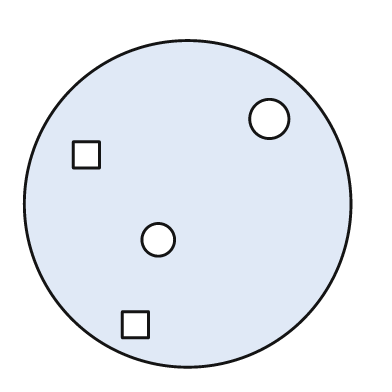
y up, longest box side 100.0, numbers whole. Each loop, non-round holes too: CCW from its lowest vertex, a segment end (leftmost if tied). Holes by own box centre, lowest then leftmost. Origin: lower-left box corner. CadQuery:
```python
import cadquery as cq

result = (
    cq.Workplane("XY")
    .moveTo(50.0, 50.0)
    .circle(50.0)
    .moveTo(30.0, 9.0)
    .lineTo(38.0, 9.0)
    .lineTo(38.0, 17.0)
    .lineTo(30.0, 17.0)
    .close()
    .moveTo(41.0, 39.0)
    .circle(5.0)
    .moveTo(15.0, 61.0)
    .lineTo(23.0, 61.0)
    .lineTo(23.0, 69.0)
    .lineTo(15.0, 69.0)
    .close()
    .moveTo(75.0, 76.0)
    .circle(6.0)
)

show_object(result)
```